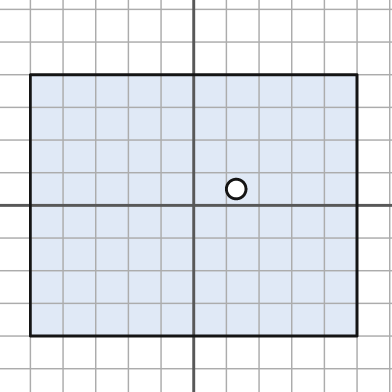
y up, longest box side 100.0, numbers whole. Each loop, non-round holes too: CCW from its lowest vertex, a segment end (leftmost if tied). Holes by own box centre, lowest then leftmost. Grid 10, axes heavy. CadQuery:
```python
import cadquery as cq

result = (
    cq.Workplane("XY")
    .moveTo(-50.0, -40.0)
    .lineTo(50.0, -40.0)
    .lineTo(50.0, 40.0)
    .lineTo(-50.0, 40.0)
    .close()
    .moveTo(13.0, 5.0)
    .circle(3.0)
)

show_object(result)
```